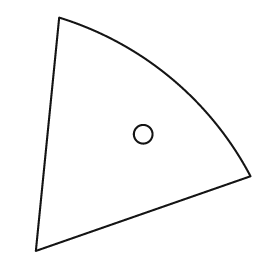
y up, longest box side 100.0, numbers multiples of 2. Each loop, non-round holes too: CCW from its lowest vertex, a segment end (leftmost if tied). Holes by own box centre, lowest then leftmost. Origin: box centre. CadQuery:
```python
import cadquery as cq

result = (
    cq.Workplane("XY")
    .moveTo(-46.0, -50.0)
    .lineTo(46.0, -18.0)
    .threePointArc((12.0, 24.0), (-36.0, 50.0))
    .close()
    .moveTo(0.0, 0.0)
    .circle(4.0)
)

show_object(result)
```